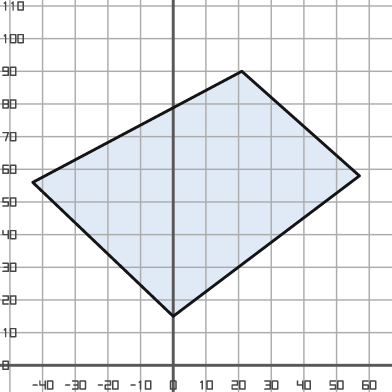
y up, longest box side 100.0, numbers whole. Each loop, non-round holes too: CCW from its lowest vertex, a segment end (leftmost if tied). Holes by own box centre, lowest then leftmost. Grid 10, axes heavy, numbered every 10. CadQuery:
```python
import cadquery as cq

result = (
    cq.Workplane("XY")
    .moveTo(0.0, 15.0)
    .lineTo(57.0, 58.0)
    .lineTo(21.0, 90.0)
    .lineTo(-43.0, 56.0)
    .close()
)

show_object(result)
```